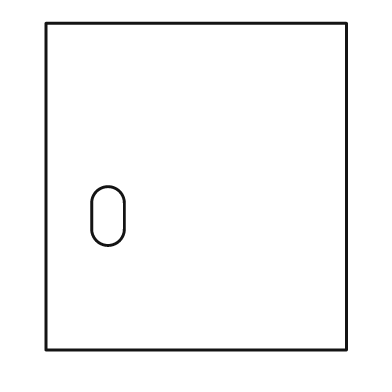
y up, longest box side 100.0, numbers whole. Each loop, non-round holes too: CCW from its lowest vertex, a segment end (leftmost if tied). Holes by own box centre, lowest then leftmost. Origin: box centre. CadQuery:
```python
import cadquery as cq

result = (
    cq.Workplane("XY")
    .moveTo(-46.0, -50.0)
    .lineTo(46.0, -50.0)
    .lineTo(46.0, 50.0)
    .lineTo(-46.0, 50.0)
    .close()
    .moveTo(-32.0, -13.0)
    .threePointArc((-27.0, -18.0), (-22.0, -13.0))
    .lineTo(-22.0, -5.0)
    .threePointArc((-27.0, 0.0), (-32.0, -5.0))
    .close()
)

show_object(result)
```